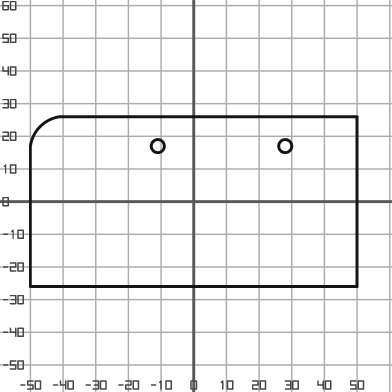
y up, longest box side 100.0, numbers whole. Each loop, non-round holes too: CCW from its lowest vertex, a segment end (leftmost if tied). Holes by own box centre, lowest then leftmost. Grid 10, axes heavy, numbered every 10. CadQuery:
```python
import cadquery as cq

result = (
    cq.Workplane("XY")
    .moveTo(-50.0, -26.0)
    .lineTo(50.0, -26.0)
    .lineTo(50.0, 26.0)
    .lineTo(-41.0, 26.0)
    .threePointArc((-47.0, 23.0), (-50.0, 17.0))
    .close()
    .moveTo(-11.0, 17.0)
    .circle(2.0)
    .moveTo(28.0, 17.0)
    .circle(2.0)
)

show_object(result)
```